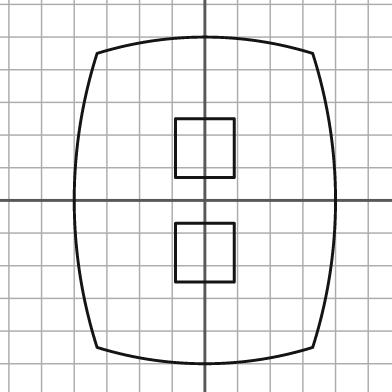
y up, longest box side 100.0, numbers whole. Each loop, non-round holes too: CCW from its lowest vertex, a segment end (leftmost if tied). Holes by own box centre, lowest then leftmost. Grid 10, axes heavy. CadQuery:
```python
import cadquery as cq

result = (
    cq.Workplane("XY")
    .moveTo(-33.0, -45.0)
    .threePointArc((0.0, -50.0), (33.0, -45.0))
    .threePointArc((40.0, 0.0), (33.0, 45.0))
    .threePointArc((0.0, 50.0), (-33.0, 45.0))
    .threePointArc((-40.0, 0.0), (-33.0, -45.0))
    .close()
    .moveTo(-9.0, -25.0)
    .lineTo(9.0, -25.0)
    .lineTo(9.0, -7.0)
    .lineTo(-9.0, -7.0)
    .close()
    .moveTo(-9.0, 7.0)
    .lineTo(9.0, 7.0)
    .lineTo(9.0, 25.0)
    .lineTo(-9.0, 25.0)
    .close()
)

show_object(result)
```